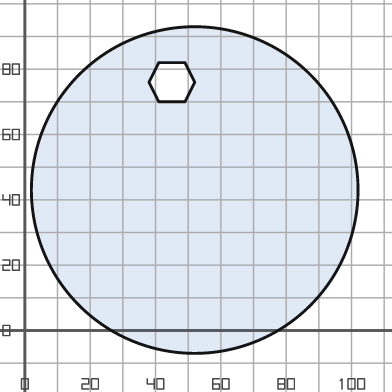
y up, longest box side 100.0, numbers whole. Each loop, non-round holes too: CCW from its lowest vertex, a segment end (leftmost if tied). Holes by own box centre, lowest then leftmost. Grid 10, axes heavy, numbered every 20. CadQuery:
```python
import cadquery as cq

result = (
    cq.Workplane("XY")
    .moveTo(52.0, 43.0)
    .circle(50.0)
    .moveTo(41.0, 70.0)
    .lineTo(49.0, 70.0)
    .lineTo(52.0, 76.0)
    .lineTo(49.0, 82.0)
    .lineTo(41.0, 82.0)
    .lineTo(38.0, 76.0)
    .close()
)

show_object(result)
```